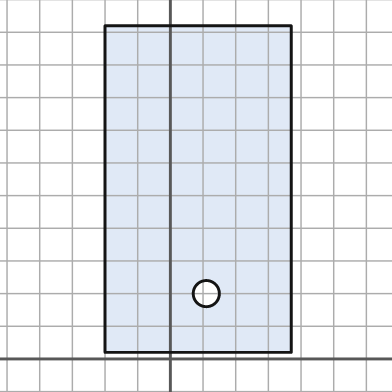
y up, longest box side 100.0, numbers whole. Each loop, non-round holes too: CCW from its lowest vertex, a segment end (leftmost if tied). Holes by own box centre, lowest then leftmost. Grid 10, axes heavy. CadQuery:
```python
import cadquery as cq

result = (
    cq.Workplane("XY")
    .moveTo(-20.0, 2.0)
    .lineTo(37.0, 2.0)
    .lineTo(37.0, 102.0)
    .lineTo(-20.0, 102.0)
    .close()
    .moveTo(11.0, 20.0)
    .circle(4.0)
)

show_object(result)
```